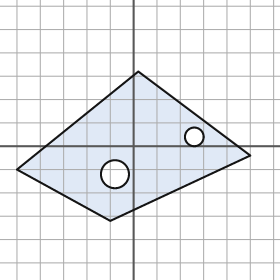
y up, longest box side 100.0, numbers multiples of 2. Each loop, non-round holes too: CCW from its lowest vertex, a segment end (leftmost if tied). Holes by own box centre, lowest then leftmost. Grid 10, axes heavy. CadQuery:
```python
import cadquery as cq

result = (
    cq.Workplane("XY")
    .moveTo(-10.0, -32.0)
    .lineTo(50.0, -4.0)
    .lineTo(2.0, 32.0)
    .lineTo(-50.0, -10.0)
    .close()
    .moveTo(-8.0, -12.0)
    .circle(6.0)
    .moveTo(26.0, 4.0)
    .circle(4.0)
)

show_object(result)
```